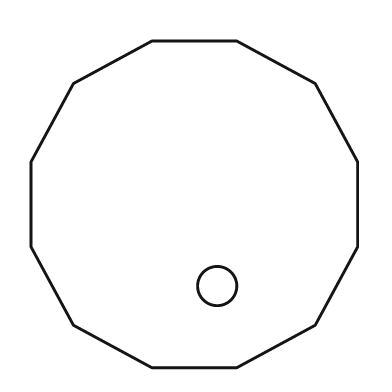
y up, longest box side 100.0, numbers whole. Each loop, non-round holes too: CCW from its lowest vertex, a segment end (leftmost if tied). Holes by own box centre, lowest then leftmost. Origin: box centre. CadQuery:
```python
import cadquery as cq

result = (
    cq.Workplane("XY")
    .moveTo(-13.0, -50.0)
    .lineTo(13.0, -50.0)
    .lineTo(37.0, -37.0)
    .lineTo(50.0, -13.0)
    .lineTo(50.0, 13.0)
    .lineTo(37.0, 37.0)
    .lineTo(13.0, 50.0)
    .lineTo(-13.0, 50.0)
    .lineTo(-37.0, 37.0)
    .lineTo(-50.0, 13.0)
    .lineTo(-50.0, -13.0)
    .lineTo(-37.0, -37.0)
    .close()
    .moveTo(7.0, -25.0)
    .circle(6.0)
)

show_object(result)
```